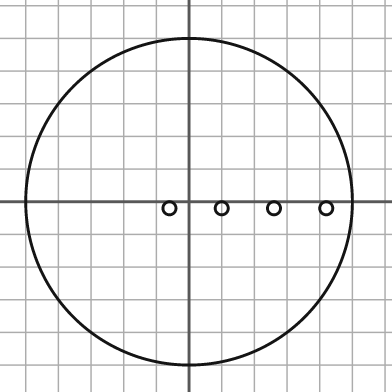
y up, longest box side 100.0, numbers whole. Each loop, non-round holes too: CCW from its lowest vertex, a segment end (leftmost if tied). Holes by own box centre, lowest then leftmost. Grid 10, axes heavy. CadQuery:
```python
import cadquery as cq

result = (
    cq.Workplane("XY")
    .moveTo(0.0, 0.0)
    .circle(50.0)
    .moveTo(-6.0, -2.0)
    .circle(2.0)
    .moveTo(10.0, -2.0)
    .circle(2.0)
    .moveTo(26.0, -2.0)
    .circle(2.0)
    .moveTo(42.0, -2.0)
    .circle(2.0)
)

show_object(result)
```